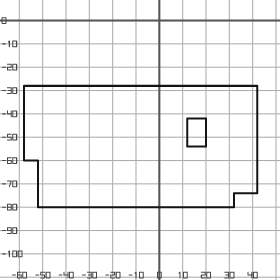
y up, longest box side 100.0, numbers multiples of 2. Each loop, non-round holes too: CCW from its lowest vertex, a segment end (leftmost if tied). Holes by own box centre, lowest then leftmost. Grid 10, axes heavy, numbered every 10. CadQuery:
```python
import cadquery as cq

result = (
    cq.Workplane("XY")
    .moveTo(-52.0, -80.0)
    .lineTo(32.0, -80.0)
    .lineTo(32.0, -74.0)
    .lineTo(42.0, -74.0)
    .lineTo(42.0, -28.0)
    .lineTo(-58.0, -28.0)
    .lineTo(-58.0, -60.0)
    .lineTo(-52.0, -60.0)
    .close()
    .moveTo(12.0, -54.0)
    .lineTo(20.0, -54.0)
    .lineTo(20.0, -42.0)
    .lineTo(12.0, -42.0)
    .close()
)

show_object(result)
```